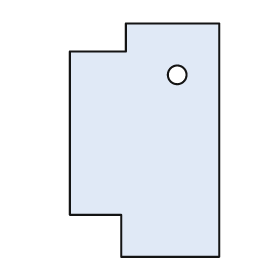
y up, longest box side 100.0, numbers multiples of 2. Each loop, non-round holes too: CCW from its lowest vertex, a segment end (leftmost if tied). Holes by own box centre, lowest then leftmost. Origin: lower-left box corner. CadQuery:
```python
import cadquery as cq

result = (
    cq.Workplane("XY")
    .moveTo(22.0, 0.0)
    .lineTo(64.0, 0.0)
    .lineTo(64.0, 100.0)
    .lineTo(24.0, 100.0)
    .lineTo(24.0, 88.0)
    .lineTo(0.0, 88.0)
    .lineTo(0.0, 18.0)
    .lineTo(22.0, 18.0)
    .close()
    .moveTo(46.0, 78.0)
    .circle(4.0)
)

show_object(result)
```